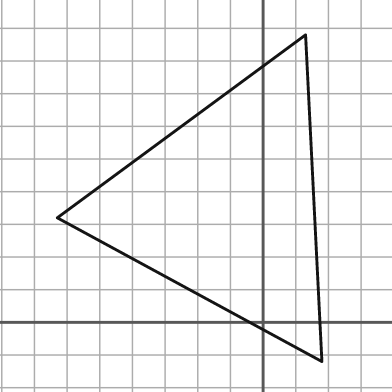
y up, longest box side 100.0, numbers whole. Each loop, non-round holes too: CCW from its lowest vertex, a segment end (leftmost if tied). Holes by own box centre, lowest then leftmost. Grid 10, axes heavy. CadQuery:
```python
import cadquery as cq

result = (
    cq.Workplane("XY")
    .moveTo(18.0, -12.0)
    .lineTo(13.0, 88.0)
    .lineTo(-63.0, 32.0)
    .close()
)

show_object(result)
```